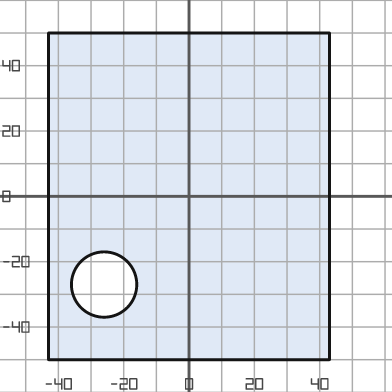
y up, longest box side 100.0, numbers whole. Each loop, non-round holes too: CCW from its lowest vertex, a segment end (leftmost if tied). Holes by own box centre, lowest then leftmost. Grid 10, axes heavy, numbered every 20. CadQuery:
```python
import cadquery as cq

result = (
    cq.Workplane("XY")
    .moveTo(-43.0, -50.0)
    .lineTo(43.0, -50.0)
    .lineTo(43.0, 50.0)
    .lineTo(-43.0, 50.0)
    .close()
    .moveTo(-26.0, -27.0)
    .circle(10.0)
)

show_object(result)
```